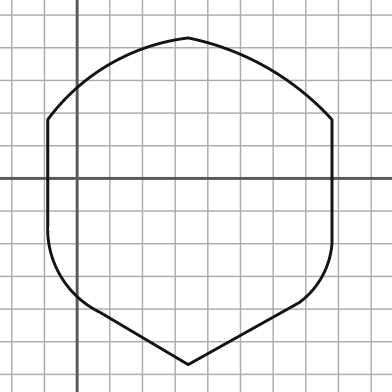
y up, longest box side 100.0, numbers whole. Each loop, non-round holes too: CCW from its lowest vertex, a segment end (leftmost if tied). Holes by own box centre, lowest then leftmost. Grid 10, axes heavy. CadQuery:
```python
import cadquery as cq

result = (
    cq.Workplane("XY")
    .moveTo(34.0, -57.0)
    .lineTo(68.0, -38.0)
    .threePointArc((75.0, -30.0), (78.0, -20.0))
    .lineTo(78.0, 18.0)
    .threePointArc((58.0, 34.0), (34.0, 43.0))
    .threePointArc((10.0, 35.0), (-9.0, 18.0))
    .lineTo(-9.0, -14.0)
    .threePointArc((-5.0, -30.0), (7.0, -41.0))
    .close()
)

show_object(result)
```